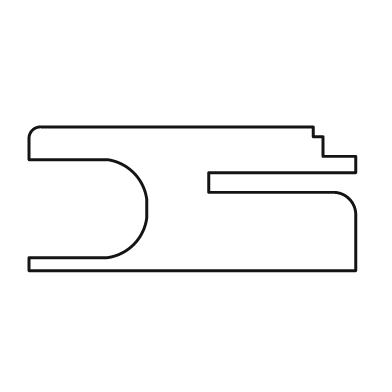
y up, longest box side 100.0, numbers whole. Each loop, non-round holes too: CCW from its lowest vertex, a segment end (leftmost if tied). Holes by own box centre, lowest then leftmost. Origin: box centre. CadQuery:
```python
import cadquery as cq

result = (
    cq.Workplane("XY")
    .moveTo(-50.0, -22.0)
    .lineTo(50.0, -22.0)
    .lineTo(50.0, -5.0)
    .threePointArc((48.0, 0.0), (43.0, 2.0))
    .lineTo(5.0, 2.0)
    .lineTo(5.0, 8.0)
    .lineTo(50.0, 8.0)
    .lineTo(50.0, 13.0)
    .lineTo(40.0, 13.0)
    .lineTo(40.0, 19.0)
    .lineTo(37.0, 19.0)
    .lineTo(37.0, 22.0)
    .lineTo(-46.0, 22.0)
    .threePointArc((-49.0, 21.0), (-50.0, 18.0))
    .lineTo(-50.0, 12.0)
    .lineTo(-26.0, 12.0)
    .threePointArc((-18.0, 8.0), (-14.0, 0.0))
    .lineTo(-14.0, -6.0)
    .threePointArc((-18.0, -14.0), (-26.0, -18.0))
    .lineTo(-50.0, -18.0)
    .close()
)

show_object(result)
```